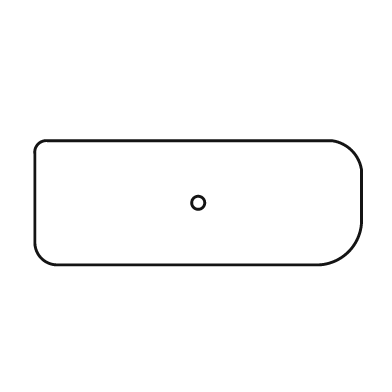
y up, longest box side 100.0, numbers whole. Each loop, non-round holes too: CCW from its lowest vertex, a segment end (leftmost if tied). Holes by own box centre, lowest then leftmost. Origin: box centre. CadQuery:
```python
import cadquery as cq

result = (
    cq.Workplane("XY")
    .moveTo(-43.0, -19.0)
    .lineTo(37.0, -19.0)
    .threePointArc((46.0, -15.0), (50.0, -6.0))
    .lineTo(50.0, 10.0)
    .threePointArc((47.0, 16.0), (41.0, 19.0))
    .lineTo(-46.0, 19.0)
    .threePointArc((-49.0, 18.0), (-50.0, 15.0))
    .lineTo(-50.0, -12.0)
    .threePointArc((-48.0, -17.0), (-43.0, -19.0))
    .close()
    .moveTo(0.0, 0.0)
    .circle(2.0)
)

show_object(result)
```